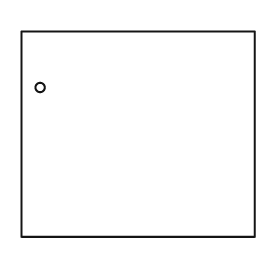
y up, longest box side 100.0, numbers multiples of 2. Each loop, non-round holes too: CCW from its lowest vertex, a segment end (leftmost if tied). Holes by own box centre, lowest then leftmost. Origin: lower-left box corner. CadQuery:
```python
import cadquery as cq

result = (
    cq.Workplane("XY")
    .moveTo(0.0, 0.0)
    .lineTo(100.0, 0.0)
    .lineTo(100.0, 88.0)
    .lineTo(0.0, 88.0)
    .close()
    .moveTo(8.0, 64.0)
    .circle(2.0)
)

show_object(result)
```